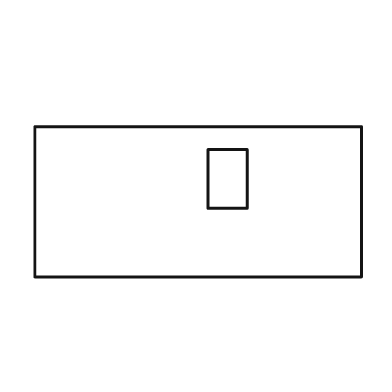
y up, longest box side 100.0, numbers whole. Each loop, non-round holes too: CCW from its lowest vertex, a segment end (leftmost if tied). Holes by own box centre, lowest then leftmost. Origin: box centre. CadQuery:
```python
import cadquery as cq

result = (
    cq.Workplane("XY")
    .moveTo(-50.0, -23.0)
    .lineTo(50.0, -23.0)
    .lineTo(50.0, 23.0)
    .lineTo(-50.0, 23.0)
    .close()
    .moveTo(3.0, -2.0)
    .lineTo(15.0, -2.0)
    .lineTo(15.0, 16.0)
    .lineTo(3.0, 16.0)
    .close()
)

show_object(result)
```